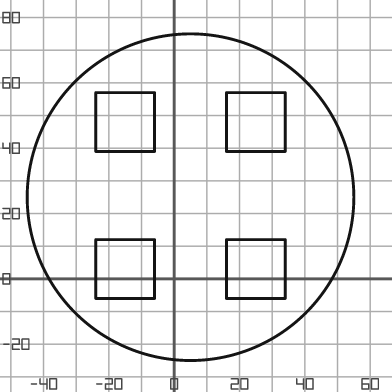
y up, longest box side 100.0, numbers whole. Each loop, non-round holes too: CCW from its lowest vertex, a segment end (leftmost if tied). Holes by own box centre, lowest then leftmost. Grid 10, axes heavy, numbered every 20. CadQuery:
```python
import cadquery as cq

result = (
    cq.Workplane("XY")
    .moveTo(5.0, 25.0)
    .circle(50.0)
    .moveTo(-24.0, -6.0)
    .lineTo(-6.0, -6.0)
    .lineTo(-6.0, 12.0)
    .lineTo(-24.0, 12.0)
    .close()
    .moveTo(16.0, -6.0)
    .lineTo(34.0, -6.0)
    .lineTo(34.0, 12.0)
    .lineTo(16.0, 12.0)
    .close()
    .moveTo(-24.0, 39.0)
    .lineTo(-6.0, 39.0)
    .lineTo(-6.0, 57.0)
    .lineTo(-24.0, 57.0)
    .close()
    .moveTo(16.0, 39.0)
    .lineTo(34.0, 39.0)
    .lineTo(34.0, 57.0)
    .lineTo(16.0, 57.0)
    .close()
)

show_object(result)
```